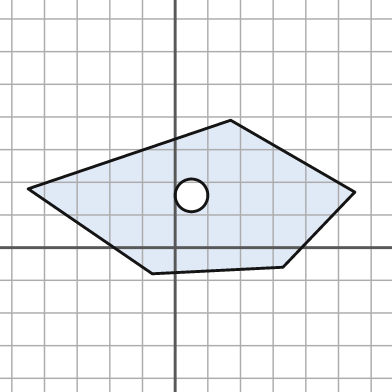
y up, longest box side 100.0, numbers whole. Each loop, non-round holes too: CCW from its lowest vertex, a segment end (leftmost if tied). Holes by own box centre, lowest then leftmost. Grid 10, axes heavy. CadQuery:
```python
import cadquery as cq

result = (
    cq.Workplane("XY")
    .moveTo(-7.0, -8.0)
    .lineTo(33.0, -6.0)
    .lineTo(55.0, 17.0)
    .lineTo(17.0, 39.0)
    .lineTo(-45.0, 18.0)
    .close()
    .moveTo(5.0, 16.0)
    .circle(5.0)
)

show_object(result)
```